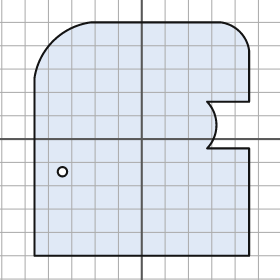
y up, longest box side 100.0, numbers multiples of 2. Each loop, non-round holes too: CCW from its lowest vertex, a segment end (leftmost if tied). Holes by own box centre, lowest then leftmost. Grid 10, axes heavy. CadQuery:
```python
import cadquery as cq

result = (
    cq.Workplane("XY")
    .moveTo(-46.0, -50.0)
    .lineTo(46.0, -50.0)
    .lineTo(46.0, -4.0)
    .lineTo(28.0, -4.0)
    .threePointArc((32.0, 6.0), (28.0, 16.0))
    .lineTo(46.0, 16.0)
    .lineTo(46.0, 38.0)
    .threePointArc((42.0, 46.0), (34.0, 50.0))
    .lineTo(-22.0, 50.0)
    .threePointArc((-38.0, 42.0), (-46.0, 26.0))
    .close()
    .moveTo(-34.0, -14.0)
    .circle(2.0)
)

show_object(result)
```